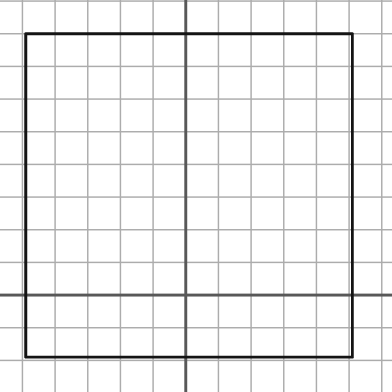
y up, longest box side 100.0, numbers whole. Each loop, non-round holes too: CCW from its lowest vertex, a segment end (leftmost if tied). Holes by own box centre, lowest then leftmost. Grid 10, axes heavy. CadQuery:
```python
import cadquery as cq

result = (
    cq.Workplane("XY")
    .moveTo(-49.0, -19.0)
    .lineTo(51.0, -19.0)
    .lineTo(51.0, 80.0)
    .lineTo(-49.0, 80.0)
    .close()
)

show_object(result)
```